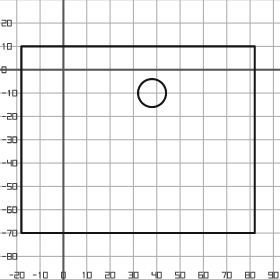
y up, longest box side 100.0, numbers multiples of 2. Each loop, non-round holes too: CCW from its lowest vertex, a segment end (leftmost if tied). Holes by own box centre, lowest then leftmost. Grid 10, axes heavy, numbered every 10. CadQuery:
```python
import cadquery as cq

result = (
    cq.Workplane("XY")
    .moveTo(-18.0, -70.0)
    .lineTo(82.0, -70.0)
    .lineTo(82.0, 10.0)
    .lineTo(-18.0, 10.0)
    .close()
    .moveTo(38.0, -10.0)
    .circle(6.0)
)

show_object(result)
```